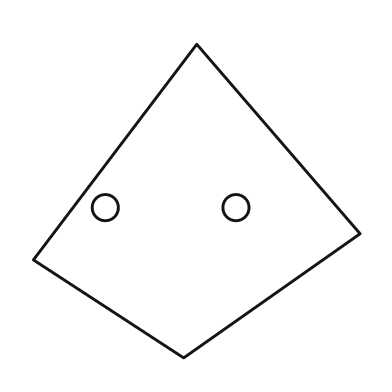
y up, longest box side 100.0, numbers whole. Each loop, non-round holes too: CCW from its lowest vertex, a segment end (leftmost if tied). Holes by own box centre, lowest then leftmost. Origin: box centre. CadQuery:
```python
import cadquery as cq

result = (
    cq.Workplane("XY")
    .moveTo(-4.0, -48.0)
    .lineTo(50.0, -10.0)
    .lineTo(0.0, 48.0)
    .lineTo(-50.0, -18.0)
    .close()
    .moveTo(-28.0, -2.0)
    .circle(4.0)
    .moveTo(12.0, -2.0)
    .circle(4.0)
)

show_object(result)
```